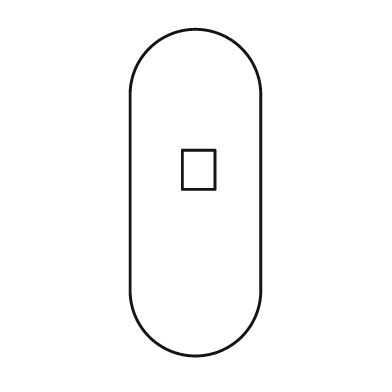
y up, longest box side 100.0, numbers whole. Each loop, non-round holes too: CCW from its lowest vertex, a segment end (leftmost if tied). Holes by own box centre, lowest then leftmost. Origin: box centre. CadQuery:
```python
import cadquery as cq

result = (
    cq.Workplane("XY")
    .moveTo(-20.0, -30.0)
    .threePointArc((0.0, -50.0), (20.0, -30.0))
    .lineTo(20.0, 30.0)
    .threePointArc((0.0, 50.0), (-20.0, 30.0))
    .close()
    .moveTo(-4.0, 1.0)
    .lineTo(6.0, 1.0)
    .lineTo(6.0, 13.0)
    .lineTo(-4.0, 13.0)
    .close()
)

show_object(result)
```